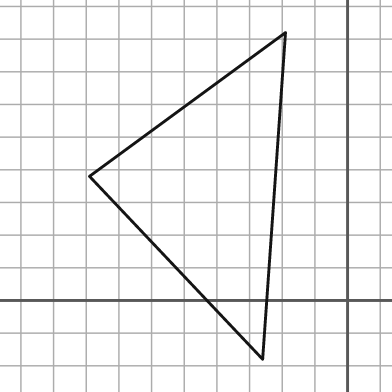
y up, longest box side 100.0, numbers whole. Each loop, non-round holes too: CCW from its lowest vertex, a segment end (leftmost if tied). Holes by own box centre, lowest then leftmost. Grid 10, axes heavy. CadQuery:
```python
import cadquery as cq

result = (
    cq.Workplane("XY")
    .moveTo(-26.0, -18.0)
    .lineTo(-19.0, 82.0)
    .lineTo(-79.0, 38.0)
    .close()
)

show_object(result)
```